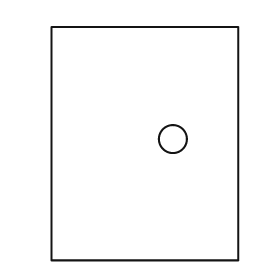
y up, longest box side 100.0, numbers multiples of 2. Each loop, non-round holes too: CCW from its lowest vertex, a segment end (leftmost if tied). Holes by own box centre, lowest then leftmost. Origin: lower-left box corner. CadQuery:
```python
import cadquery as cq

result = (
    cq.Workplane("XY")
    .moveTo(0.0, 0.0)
    .lineTo(80.0, 0.0)
    .lineTo(80.0, 100.0)
    .lineTo(0.0, 100.0)
    .close()
    .moveTo(52.0, 52.0)
    .circle(6.0)
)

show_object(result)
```